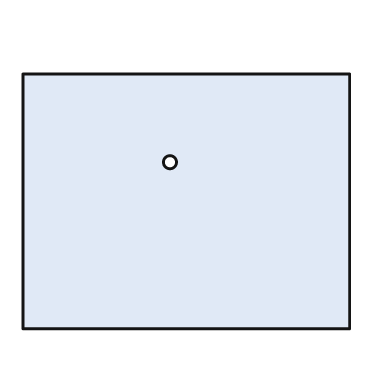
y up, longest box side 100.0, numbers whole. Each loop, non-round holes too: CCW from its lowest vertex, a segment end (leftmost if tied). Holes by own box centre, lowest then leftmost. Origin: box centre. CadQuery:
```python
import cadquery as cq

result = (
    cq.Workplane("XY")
    .moveTo(-50.0, -39.0)
    .lineTo(50.0, -39.0)
    .lineTo(50.0, 39.0)
    .lineTo(-50.0, 39.0)
    .close()
    .moveTo(-5.0, 12.0)
    .circle(2.0)
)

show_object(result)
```